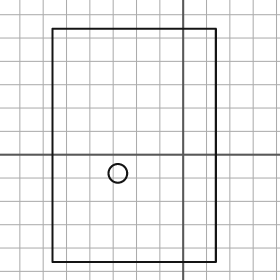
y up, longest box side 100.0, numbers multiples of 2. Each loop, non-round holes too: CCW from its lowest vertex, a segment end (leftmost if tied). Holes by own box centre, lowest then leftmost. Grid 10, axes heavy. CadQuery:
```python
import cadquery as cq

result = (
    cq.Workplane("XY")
    .moveTo(-56.0, -46.0)
    .lineTo(14.0, -46.0)
    .lineTo(14.0, 54.0)
    .lineTo(-56.0, 54.0)
    .close()
    .moveTo(-28.0, -8.0)
    .circle(4.0)
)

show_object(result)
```